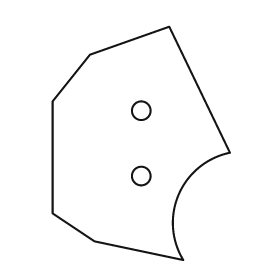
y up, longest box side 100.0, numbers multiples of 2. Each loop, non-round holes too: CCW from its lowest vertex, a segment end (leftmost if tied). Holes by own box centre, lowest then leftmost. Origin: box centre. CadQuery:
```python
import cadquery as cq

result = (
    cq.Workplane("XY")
    .moveTo(18.0, -50.0)
    .threePointArc((16.0, -22.0), (38.0, -4.0))
    .lineTo(12.0, 50.0)
    .lineTo(-22.0, 38.0)
    .lineTo(-38.0, 18.0)
    .lineTo(-38.0, -30.0)
    .lineTo(-20.0, -42.0)
    .close()
    .moveTo(0.0, -14.0)
    .circle(4.0)
    .moveTo(0.0, 14.0)
    .circle(4.0)
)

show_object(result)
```